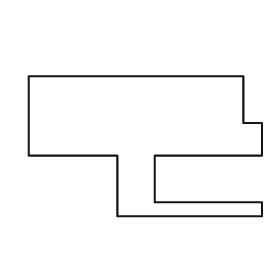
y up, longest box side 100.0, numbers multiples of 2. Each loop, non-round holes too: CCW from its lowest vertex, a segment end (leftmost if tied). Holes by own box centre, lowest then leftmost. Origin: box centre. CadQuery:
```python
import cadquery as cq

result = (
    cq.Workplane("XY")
    .moveTo(-12.0, -30.0)
    .lineTo(50.0, -30.0)
    .lineTo(50.0, -24.0)
    .lineTo(4.0, -24.0)
    .lineTo(4.0, -4.0)
    .lineTo(50.0, -4.0)
    .lineTo(50.0, 10.0)
    .lineTo(42.0, 10.0)
    .lineTo(42.0, 30.0)
    .lineTo(-50.0, 30.0)
    .lineTo(-50.0, -4.0)
    .lineTo(-12.0, -4.0)
    .close()
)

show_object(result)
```